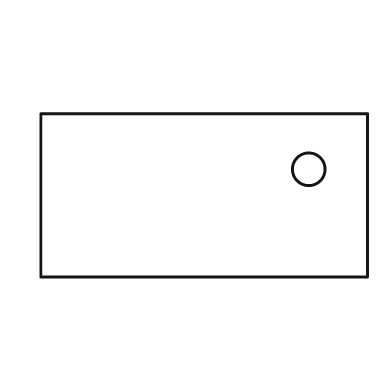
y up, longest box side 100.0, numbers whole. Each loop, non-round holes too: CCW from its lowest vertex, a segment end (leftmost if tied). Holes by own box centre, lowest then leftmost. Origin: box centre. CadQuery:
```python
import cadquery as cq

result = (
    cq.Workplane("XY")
    .moveTo(-50.0, -25.0)
    .lineTo(50.0, -25.0)
    .lineTo(50.0, 25.0)
    .lineTo(-50.0, 25.0)
    .close()
    .moveTo(32.0, 8.0)
    .circle(5.0)
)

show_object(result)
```